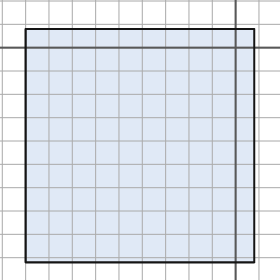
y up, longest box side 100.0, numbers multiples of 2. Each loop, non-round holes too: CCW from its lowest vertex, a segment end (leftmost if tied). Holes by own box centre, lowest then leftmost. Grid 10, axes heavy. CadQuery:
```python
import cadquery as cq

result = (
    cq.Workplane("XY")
    .moveTo(-90.0, -92.0)
    .lineTo(8.0, -92.0)
    .lineTo(8.0, 8.0)
    .lineTo(-90.0, 8.0)
    .close()
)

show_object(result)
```